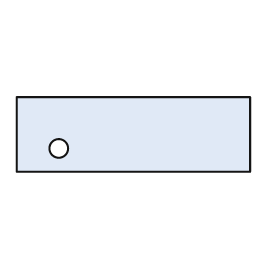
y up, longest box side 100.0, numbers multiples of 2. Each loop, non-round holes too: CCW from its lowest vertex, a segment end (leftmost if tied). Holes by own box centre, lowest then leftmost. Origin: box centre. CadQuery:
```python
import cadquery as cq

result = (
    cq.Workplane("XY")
    .moveTo(-50.0, -16.0)
    .lineTo(50.0, -16.0)
    .lineTo(50.0, 16.0)
    .lineTo(-50.0, 16.0)
    .close()
    .moveTo(-32.0, -6.0)
    .circle(4.0)
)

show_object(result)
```